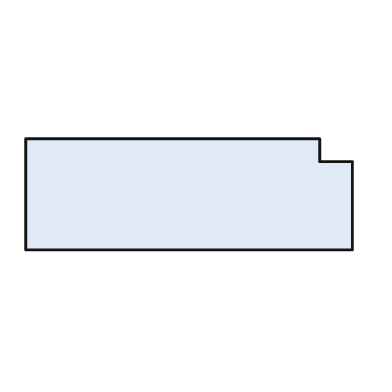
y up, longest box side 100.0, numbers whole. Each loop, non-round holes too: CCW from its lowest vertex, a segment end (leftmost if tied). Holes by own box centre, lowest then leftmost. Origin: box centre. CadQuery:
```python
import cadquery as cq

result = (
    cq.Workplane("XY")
    .moveTo(-50.0, -17.0)
    .lineTo(50.0, -17.0)
    .lineTo(50.0, 10.0)
    .lineTo(40.0, 10.0)
    .lineTo(40.0, 17.0)
    .lineTo(-50.0, 17.0)
    .close()
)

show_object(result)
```